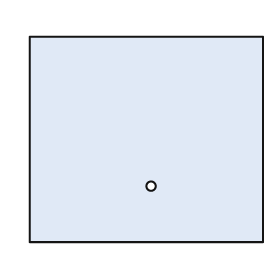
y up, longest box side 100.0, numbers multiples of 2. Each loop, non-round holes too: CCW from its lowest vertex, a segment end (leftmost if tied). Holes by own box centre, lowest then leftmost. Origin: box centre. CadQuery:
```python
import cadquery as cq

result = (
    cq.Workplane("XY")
    .moveTo(-50.0, -44.0)
    .lineTo(50.0, -44.0)
    .lineTo(50.0, 44.0)
    .lineTo(-50.0, 44.0)
    .close()
    .moveTo(2.0, -20.0)
    .circle(2.0)
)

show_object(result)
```